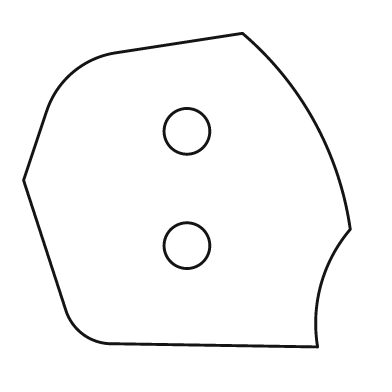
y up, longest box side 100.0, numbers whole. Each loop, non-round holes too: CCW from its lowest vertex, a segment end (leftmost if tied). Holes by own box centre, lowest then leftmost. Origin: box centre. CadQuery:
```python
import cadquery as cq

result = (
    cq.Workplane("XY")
    .moveTo(40.0, -48.0)
    .threePointArc((41.0, -29.0), (50.0, -12.0))
    .threePointArc((39.0, 21.0), (17.0, 48.0))
    .lineTo(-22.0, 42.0)
    .threePointArc((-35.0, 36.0), (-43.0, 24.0))
    .lineTo(-50.0, 3.0)
    .lineTo(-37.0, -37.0)
    .threePointArc((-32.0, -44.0), (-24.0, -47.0))
    .close()
    .moveTo(0.0, -17.0)
    .circle(7.0)
    .moveTo(0.0, 18.0)
    .circle(7.0)
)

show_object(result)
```